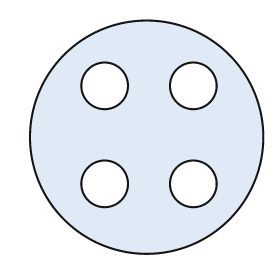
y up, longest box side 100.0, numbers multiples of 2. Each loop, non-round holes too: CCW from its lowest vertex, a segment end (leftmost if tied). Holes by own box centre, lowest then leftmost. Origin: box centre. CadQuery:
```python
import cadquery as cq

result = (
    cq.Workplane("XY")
    .moveTo(0.0, 0.0)
    .circle(50.0)
    .moveTo(-18.0, -20.0)
    .circle(10.0)
    .moveTo(20.0, -20.0)
    .circle(10.0)
    .moveTo(-18.0, 22.0)
    .circle(10.0)
    .moveTo(20.0, 22.0)
    .circle(10.0)
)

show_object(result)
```